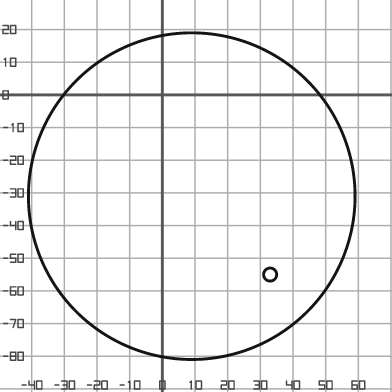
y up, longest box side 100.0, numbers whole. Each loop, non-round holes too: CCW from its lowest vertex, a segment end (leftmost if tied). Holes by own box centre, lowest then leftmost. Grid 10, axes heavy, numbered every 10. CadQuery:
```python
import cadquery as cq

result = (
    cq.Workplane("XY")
    .moveTo(9.0, -31.0)
    .circle(50.0)
    .moveTo(33.0, -55.0)
    .circle(2.0)
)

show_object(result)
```